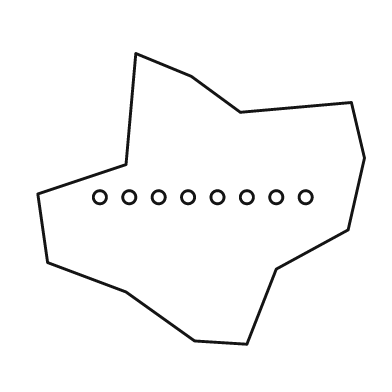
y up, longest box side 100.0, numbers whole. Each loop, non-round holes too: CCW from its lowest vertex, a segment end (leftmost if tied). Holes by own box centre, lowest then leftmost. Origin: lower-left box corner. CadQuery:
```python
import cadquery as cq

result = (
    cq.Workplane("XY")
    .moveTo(64.0, 0.0)
    .lineTo(73.0, 23.0)
    .lineTo(95.0, 35.0)
    .lineTo(100.0, 57.0)
    .lineTo(96.0, 74.0)
    .lineTo(62.0, 71.0)
    .lineTo(47.0, 82.0)
    .lineTo(30.0, 89.0)
    .lineTo(27.0, 55.0)
    .lineTo(0.0, 46.0)
    .lineTo(3.0, 25.0)
    .lineTo(27.0, 16.0)
    .lineTo(48.0, 1.0)
    .close()
    .moveTo(19.0, 45.0)
    .circle(2.0)
    .moveTo(28.0, 45.0)
    .circle(2.0)
    .moveTo(37.0, 45.0)
    .circle(2.0)
    .moveTo(46.0, 45.0)
    .circle(2.0)
    .moveTo(55.0, 45.0)
    .circle(2.0)
    .moveTo(64.0, 45.0)
    .circle(2.0)
    .moveTo(73.0, 45.0)
    .circle(2.0)
    .moveTo(82.0, 45.0)
    .circle(2.0)
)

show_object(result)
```